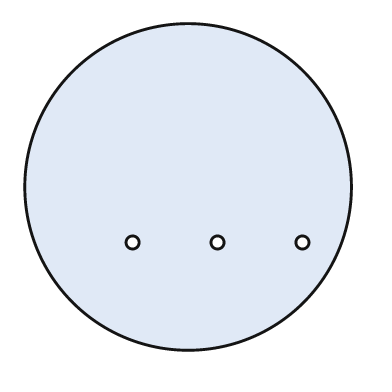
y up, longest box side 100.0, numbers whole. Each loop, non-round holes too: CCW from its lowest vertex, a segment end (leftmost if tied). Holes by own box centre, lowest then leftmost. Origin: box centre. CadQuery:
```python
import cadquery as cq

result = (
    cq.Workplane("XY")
    .moveTo(0.0, 0.0)
    .circle(50.0)
    .moveTo(-17.0, -17.0)
    .circle(2.0)
    .moveTo(9.0, -17.0)
    .circle(2.0)
    .moveTo(35.0, -17.0)
    .circle(2.0)
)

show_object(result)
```